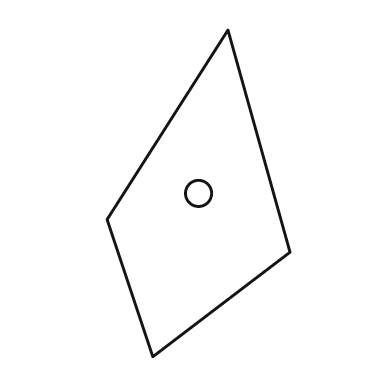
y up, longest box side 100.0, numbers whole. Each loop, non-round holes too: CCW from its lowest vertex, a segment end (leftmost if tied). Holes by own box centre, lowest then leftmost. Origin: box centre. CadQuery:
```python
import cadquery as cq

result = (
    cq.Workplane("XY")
    .moveTo(-14.0, -50.0)
    .lineTo(28.0, -18.0)
    .lineTo(9.0, 50.0)
    .lineTo(-28.0, -8.0)
    .close()
    .moveTo(0.0, 0.0)
    .circle(4.0)
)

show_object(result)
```